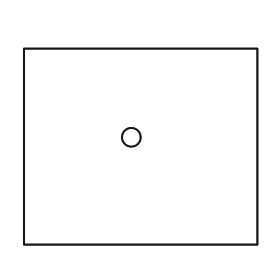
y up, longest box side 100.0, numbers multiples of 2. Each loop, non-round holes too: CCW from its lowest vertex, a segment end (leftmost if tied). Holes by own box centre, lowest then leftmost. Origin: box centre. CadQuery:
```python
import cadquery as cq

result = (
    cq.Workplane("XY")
    .moveTo(-50.0, -42.0)
    .lineTo(50.0, -42.0)
    .lineTo(50.0, 42.0)
    .lineTo(-50.0, 42.0)
    .close()
    .moveTo(-4.0, 4.0)
    .circle(4.0)
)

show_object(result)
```